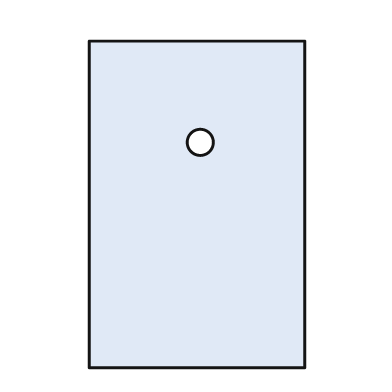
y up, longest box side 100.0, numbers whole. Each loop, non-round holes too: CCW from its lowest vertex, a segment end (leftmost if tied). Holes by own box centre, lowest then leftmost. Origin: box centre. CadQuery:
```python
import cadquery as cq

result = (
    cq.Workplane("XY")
    .moveTo(-33.0, -50.0)
    .lineTo(33.0, -50.0)
    .lineTo(33.0, 50.0)
    .lineTo(-33.0, 50.0)
    .close()
    .moveTo(1.0, 19.0)
    .circle(4.0)
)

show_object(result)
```